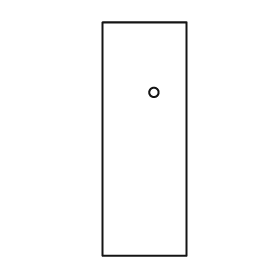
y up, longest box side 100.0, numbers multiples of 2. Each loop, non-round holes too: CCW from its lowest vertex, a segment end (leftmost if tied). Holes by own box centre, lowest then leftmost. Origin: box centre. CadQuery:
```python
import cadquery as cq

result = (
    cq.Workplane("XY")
    .moveTo(-18.0, -50.0)
    .lineTo(18.0, -50.0)
    .lineTo(18.0, 50.0)
    .lineTo(-18.0, 50.0)
    .close()
    .moveTo(4.0, 20.0)
    .circle(2.0)
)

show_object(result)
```